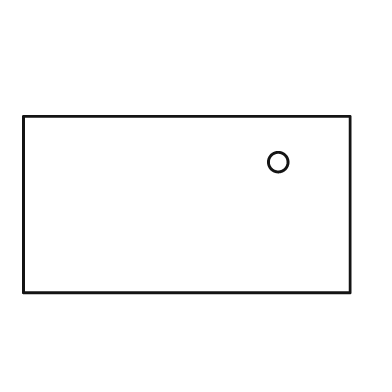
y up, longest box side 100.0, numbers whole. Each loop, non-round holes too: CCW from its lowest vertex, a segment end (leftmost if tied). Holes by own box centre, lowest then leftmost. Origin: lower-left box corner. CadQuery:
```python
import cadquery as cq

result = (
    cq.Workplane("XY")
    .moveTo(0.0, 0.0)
    .lineTo(100.0, 0.0)
    .lineTo(100.0, 54.0)
    .lineTo(0.0, 54.0)
    .close()
    .moveTo(78.0, 40.0)
    .circle(3.0)
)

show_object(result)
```